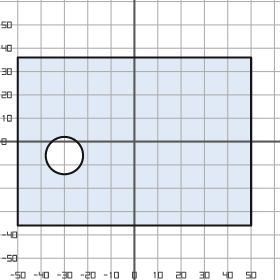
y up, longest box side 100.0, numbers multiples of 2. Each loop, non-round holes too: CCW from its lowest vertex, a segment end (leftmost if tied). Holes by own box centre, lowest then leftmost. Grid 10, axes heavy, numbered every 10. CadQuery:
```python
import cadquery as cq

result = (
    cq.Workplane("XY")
    .moveTo(-50.0, -36.0)
    .lineTo(50.0, -36.0)
    .lineTo(50.0, 36.0)
    .lineTo(-50.0, 36.0)
    .close()
    .moveTo(-30.0, -6.0)
    .circle(8.0)
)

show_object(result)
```